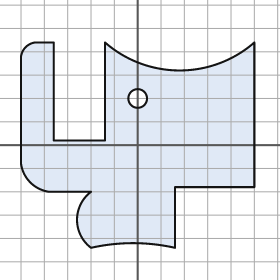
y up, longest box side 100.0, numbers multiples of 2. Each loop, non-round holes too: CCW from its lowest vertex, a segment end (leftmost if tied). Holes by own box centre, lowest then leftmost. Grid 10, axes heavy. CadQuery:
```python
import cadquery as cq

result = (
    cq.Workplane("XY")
    .moveTo(-20.0, -44.0)
    .threePointArc((-2.0, -42.0), (16.0, -44.0))
    .lineTo(16.0, -18.0)
    .lineTo(50.0, -18.0)
    .lineTo(50.0, 44.0)
    .threePointArc((18.0, 32.0), (-14.0, 44.0))
    .lineTo(-14.0, 2.0)
    .lineTo(-36.0, 2.0)
    .lineTo(-36.0, 44.0)
    .lineTo(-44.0, 44.0)
    .threePointArc((-48.0, 42.0), (-50.0, 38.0))
    .lineTo(-50.0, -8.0)
    .threePointArc((-46.0, -16.0), (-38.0, -20.0))
    .lineTo(-20.0, -20.0)
    .threePointArc((-26.0, -32.0), (-20.0, -44.0))
    .close()
    .moveTo(0.0, 20.0)
    .circle(4.0)
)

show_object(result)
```